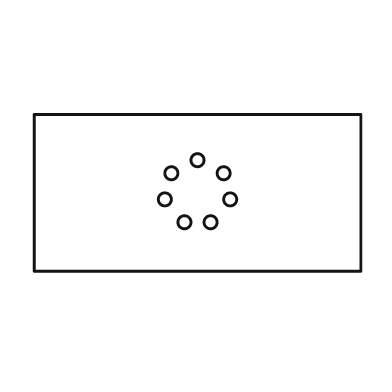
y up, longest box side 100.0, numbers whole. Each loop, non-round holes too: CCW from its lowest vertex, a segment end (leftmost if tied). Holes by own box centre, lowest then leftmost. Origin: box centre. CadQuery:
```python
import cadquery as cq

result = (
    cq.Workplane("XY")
    .moveTo(-50.0, -24.0)
    .lineTo(50.0, -24.0)
    .lineTo(50.0, 24.0)
    .lineTo(-50.0, 24.0)
    .close()
    .moveTo(-4.0, -9.0)
    .circle(2.0)
    .moveTo(4.0, -9.0)
    .circle(2.0)
    .moveTo(-10.0, -2.0)
    .circle(2.0)
    .moveTo(10.0, -2.0)
    .circle(2.0)
    .moveTo(-8.0, 6.0)
    .circle(2.0)
    .moveTo(8.0, 6.0)
    .circle(2.0)
    .moveTo(0.0, 10.0)
    .circle(2.0)
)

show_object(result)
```